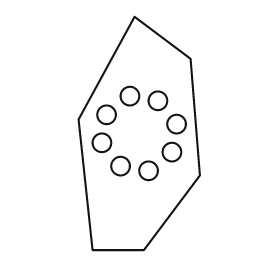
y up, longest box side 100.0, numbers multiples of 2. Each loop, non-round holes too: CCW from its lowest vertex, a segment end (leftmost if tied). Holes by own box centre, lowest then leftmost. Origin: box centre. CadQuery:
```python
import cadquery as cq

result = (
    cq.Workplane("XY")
    .moveTo(-20.0, -50.0)
    .lineTo(2.0, -50.0)
    .lineTo(26.0, -18.0)
    .lineTo(22.0, 32.0)
    .lineTo(-2.0, 50.0)
    .lineTo(-26.0, 6.0)
    .close()
    .moveTo(4.0, -16.0)
    .circle(4.0)
    .moveTo(-8.0, -14.0)
    .circle(4.0)
    .moveTo(14.0, -8.0)
    .circle(4.0)
    .moveTo(-16.0, -4.0)
    .circle(4.0)
    .moveTo(16.0, 4.0)
    .circle(4.0)
    .moveTo(-14.0, 8.0)
    .circle(4.0)
    .moveTo(8.0, 14.0)
    .circle(4.0)
    .moveTo(-4.0, 16.0)
    .circle(4.0)
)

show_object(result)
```